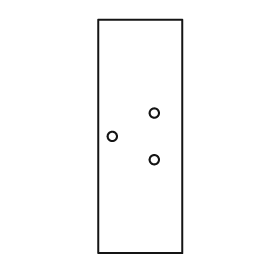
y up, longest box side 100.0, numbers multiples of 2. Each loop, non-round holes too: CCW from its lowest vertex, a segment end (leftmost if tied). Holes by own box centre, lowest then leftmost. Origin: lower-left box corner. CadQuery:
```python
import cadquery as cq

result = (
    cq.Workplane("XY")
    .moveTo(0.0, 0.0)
    .lineTo(36.0, 0.0)
    .lineTo(36.0, 100.0)
    .lineTo(0.0, 100.0)
    .close()
    .moveTo(24.0, 40.0)
    .circle(2.0)
    .moveTo(6.0, 50.0)
    .circle(2.0)
    .moveTo(24.0, 60.0)
    .circle(2.0)
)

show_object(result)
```